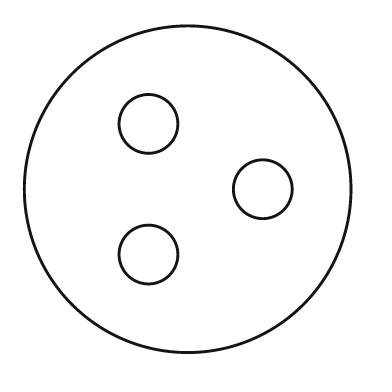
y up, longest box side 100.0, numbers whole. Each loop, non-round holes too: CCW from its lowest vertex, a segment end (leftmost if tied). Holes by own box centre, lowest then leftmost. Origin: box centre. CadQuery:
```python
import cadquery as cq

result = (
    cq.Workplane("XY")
    .moveTo(0.0, 0.0)
    .circle(50.0)
    .moveTo(-12.0, -20.0)
    .circle(9.0)
    .moveTo(23.0, 0.0)
    .circle(9.0)
    .moveTo(-12.0, 20.0)
    .circle(9.0)
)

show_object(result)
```